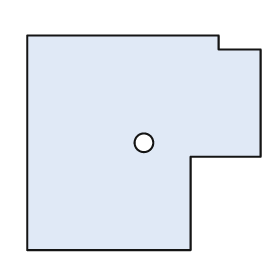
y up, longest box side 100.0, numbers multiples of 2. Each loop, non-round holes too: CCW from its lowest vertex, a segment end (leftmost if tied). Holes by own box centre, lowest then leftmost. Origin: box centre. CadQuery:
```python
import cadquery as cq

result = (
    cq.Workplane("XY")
    .moveTo(-50.0, -46.0)
    .lineTo(20.0, -46.0)
    .lineTo(20.0, -6.0)
    .lineTo(50.0, -6.0)
    .lineTo(50.0, 40.0)
    .lineTo(32.0, 40.0)
    .lineTo(32.0, 46.0)
    .lineTo(-50.0, 46.0)
    .close()
    .moveTo(0.0, 0.0)
    .circle(4.0)
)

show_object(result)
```